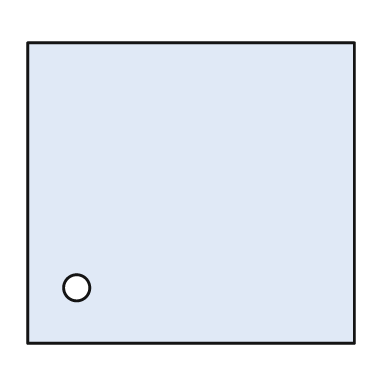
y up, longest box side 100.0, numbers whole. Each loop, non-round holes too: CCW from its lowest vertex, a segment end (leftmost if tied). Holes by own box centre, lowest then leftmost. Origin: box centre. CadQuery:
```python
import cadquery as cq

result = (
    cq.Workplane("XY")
    .moveTo(-50.0, -46.0)
    .lineTo(50.0, -46.0)
    .lineTo(50.0, 46.0)
    .lineTo(-50.0, 46.0)
    .close()
    .moveTo(-35.0, -29.0)
    .circle(4.0)
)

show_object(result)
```